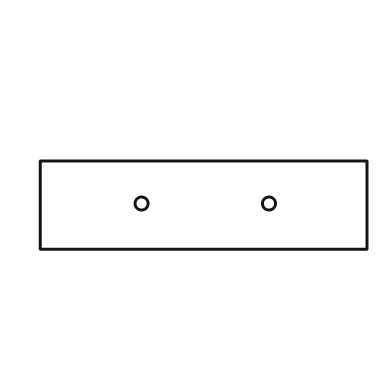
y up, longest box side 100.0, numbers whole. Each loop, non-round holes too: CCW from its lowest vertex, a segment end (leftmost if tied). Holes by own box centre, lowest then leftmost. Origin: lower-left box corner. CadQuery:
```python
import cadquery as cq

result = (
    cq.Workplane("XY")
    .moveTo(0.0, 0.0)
    .lineTo(100.0, 0.0)
    .lineTo(100.0, 27.0)
    .lineTo(0.0, 27.0)
    .close()
    .moveTo(31.0, 14.0)
    .circle(2.0)
    .moveTo(70.0, 14.0)
    .circle(2.0)
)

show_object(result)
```